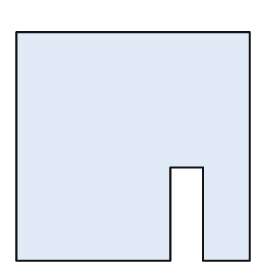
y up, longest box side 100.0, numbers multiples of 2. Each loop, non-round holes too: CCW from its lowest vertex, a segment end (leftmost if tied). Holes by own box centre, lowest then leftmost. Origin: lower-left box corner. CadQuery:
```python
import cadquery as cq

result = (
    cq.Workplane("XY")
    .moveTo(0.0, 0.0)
    .lineTo(66.0, 0.0)
    .lineTo(66.0, 40.0)
    .lineTo(80.0, 40.0)
    .lineTo(80.0, 0.0)
    .lineTo(100.0, 0.0)
    .lineTo(100.0, 98.0)
    .lineTo(0.0, 98.0)
    .close()
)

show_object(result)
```